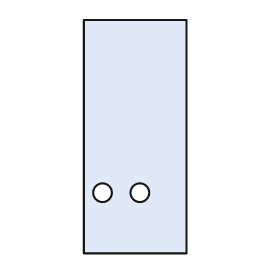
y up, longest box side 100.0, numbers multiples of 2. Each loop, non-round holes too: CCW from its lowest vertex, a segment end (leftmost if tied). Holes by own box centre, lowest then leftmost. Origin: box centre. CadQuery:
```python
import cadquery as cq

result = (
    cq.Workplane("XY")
    .moveTo(-22.0, -50.0)
    .lineTo(22.0, -50.0)
    .lineTo(22.0, 50.0)
    .lineTo(-22.0, 50.0)
    .close()
    .moveTo(-14.0, -24.0)
    .circle(4.0)
    .moveTo(2.0, -24.0)
    .circle(4.0)
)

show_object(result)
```